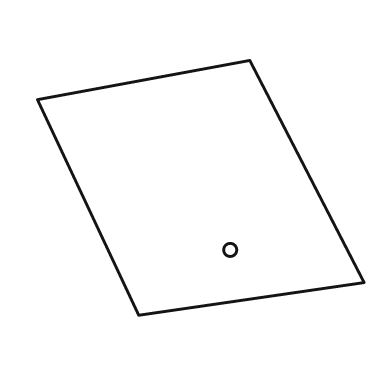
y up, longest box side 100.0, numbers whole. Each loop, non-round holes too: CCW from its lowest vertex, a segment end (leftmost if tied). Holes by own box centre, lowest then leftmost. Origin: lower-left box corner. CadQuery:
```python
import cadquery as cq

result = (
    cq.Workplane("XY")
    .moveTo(31.0, 0.0)
    .lineTo(100.0, 10.0)
    .lineTo(65.0, 78.0)
    .lineTo(0.0, 66.0)
    .close()
    .moveTo(59.0, 20.0)
    .circle(2.0)
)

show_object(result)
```